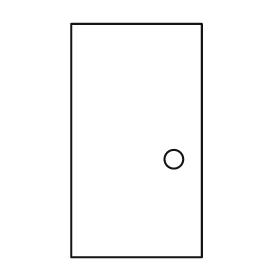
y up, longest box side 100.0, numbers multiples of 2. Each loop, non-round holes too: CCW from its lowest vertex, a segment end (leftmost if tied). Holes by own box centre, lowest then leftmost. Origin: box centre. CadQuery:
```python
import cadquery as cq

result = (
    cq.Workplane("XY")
    .moveTo(-28.0, -50.0)
    .lineTo(28.0, -50.0)
    .lineTo(28.0, 50.0)
    .lineTo(-28.0, 50.0)
    .close()
    .moveTo(16.0, -8.0)
    .circle(4.0)
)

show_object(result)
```